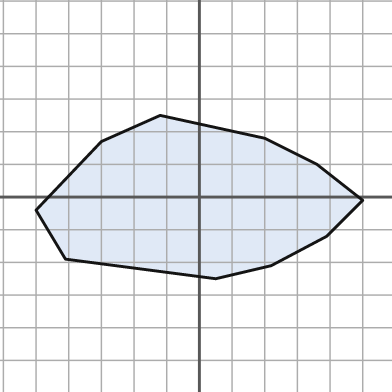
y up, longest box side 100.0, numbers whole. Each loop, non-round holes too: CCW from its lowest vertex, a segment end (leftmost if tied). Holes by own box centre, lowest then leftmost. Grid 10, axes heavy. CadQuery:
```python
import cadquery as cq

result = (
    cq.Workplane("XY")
    .moveTo(5.0, -25.0)
    .lineTo(22.0, -21.0)
    .lineTo(39.0, -12.0)
    .lineTo(50.0, -1.0)
    .lineTo(36.0, 10.0)
    .lineTo(20.0, 18.0)
    .lineTo(-12.0, 25.0)
    .lineTo(-30.0, 17.0)
    .lineTo(-50.0, -4.0)
    .lineTo(-41.0, -19.0)
    .close()
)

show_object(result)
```